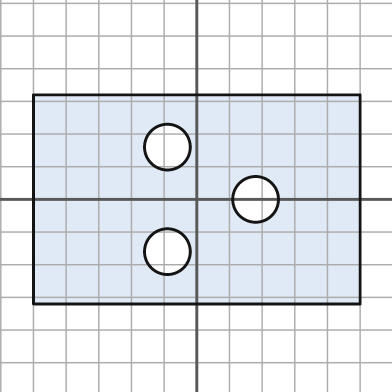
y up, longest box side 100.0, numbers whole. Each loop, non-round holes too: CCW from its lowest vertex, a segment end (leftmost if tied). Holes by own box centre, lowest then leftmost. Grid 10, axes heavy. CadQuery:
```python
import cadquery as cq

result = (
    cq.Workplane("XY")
    .moveTo(-50.0, -32.0)
    .lineTo(50.0, -32.0)
    .lineTo(50.0, 32.0)
    .lineTo(-50.0, 32.0)
    .close()
    .moveTo(-9.0, -16.0)
    .circle(7.0)
    .moveTo(18.0, 0.0)
    .circle(7.0)
    .moveTo(-9.0, 16.0)
    .circle(7.0)
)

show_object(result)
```